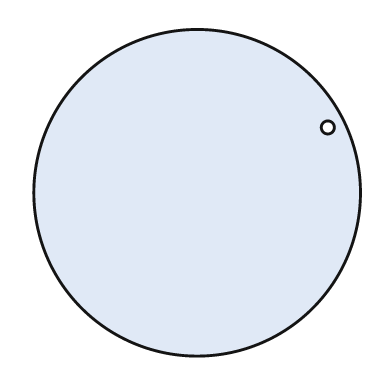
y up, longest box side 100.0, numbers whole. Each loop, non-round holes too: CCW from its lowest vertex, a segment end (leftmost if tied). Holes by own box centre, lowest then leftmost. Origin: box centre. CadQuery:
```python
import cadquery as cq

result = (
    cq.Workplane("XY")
    .moveTo(0.0, 0.0)
    .circle(50.0)
    .moveTo(40.0, 20.0)
    .circle(2.0)
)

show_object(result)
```